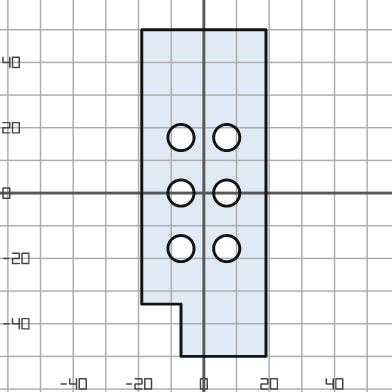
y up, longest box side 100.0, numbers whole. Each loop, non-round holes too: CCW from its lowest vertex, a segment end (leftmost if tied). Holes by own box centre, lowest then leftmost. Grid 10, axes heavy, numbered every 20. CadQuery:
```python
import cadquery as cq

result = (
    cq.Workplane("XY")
    .moveTo(-7.0, -50.0)
    .lineTo(19.0, -50.0)
    .lineTo(19.0, 50.0)
    .lineTo(-19.0, 50.0)
    .lineTo(-19.0, -34.0)
    .lineTo(-7.0, -34.0)
    .close()
    .moveTo(-7.0, -17.0)
    .circle(4.0)
    .moveTo(7.0, -17.0)
    .circle(4.0)
    .moveTo(-7.0, 0.0)
    .circle(4.0)
    .moveTo(7.0, 0.0)
    .circle(4.0)
    .moveTo(-7.0, 17.0)
    .circle(4.0)
    .moveTo(7.0, 17.0)
    .circle(4.0)
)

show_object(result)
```